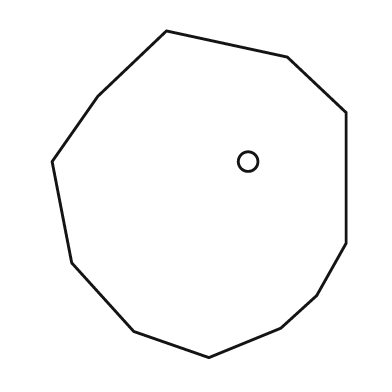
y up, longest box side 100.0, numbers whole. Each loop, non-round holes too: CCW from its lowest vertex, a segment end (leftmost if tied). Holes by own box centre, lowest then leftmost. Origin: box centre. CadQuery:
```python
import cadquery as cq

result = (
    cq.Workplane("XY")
    .moveTo(3.0, -50.0)
    .lineTo(25.0, -41.0)
    .lineTo(36.0, -31.0)
    .lineTo(45.0, -15.0)
    .lineTo(45.0, 25.0)
    .lineTo(27.0, 42.0)
    .lineTo(-10.0, 50.0)
    .lineTo(-31.0, 30.0)
    .lineTo(-45.0, 10.0)
    .lineTo(-39.0, -21.0)
    .lineTo(-20.0, -42.0)
    .close()
    .moveTo(15.0, 10.0)
    .circle(3.0)
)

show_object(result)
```